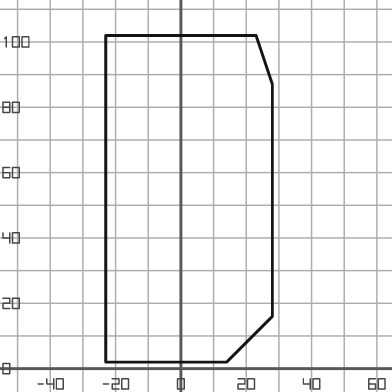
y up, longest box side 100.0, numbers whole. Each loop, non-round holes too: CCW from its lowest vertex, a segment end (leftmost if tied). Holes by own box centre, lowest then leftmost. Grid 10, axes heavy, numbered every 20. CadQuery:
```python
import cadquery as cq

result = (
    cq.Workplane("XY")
    .moveTo(-23.0, 2.0)
    .lineTo(14.0, 2.0)
    .lineTo(28.0, 16.0)
    .lineTo(28.0, 87.0)
    .lineTo(23.0, 102.0)
    .lineTo(-23.0, 102.0)
    .close()
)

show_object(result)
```